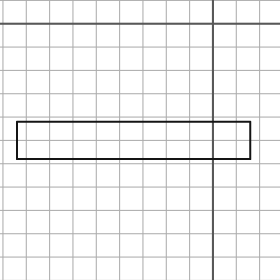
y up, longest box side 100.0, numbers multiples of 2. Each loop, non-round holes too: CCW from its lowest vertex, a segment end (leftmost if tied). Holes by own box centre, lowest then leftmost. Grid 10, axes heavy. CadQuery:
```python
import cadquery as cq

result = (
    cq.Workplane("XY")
    .moveTo(-84.0, -58.0)
    .lineTo(16.0, -58.0)
    .lineTo(16.0, -42.0)
    .lineTo(-84.0, -42.0)
    .close()
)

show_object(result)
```